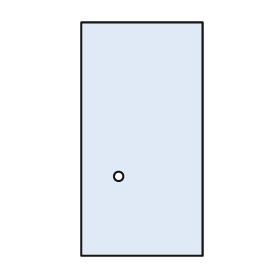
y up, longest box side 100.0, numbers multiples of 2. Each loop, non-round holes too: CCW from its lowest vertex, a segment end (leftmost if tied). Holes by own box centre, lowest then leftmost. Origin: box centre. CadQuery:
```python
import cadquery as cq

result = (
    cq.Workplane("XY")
    .moveTo(-26.0, -50.0)
    .lineTo(26.0, -50.0)
    .lineTo(26.0, 50.0)
    .lineTo(-26.0, 50.0)
    .close()
    .moveTo(-10.0, -16.0)
    .circle(2.0)
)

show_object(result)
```